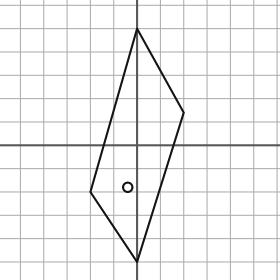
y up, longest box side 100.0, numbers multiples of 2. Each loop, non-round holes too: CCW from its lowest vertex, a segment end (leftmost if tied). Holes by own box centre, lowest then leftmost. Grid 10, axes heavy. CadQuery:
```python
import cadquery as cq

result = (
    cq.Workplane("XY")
    .moveTo(0.0, -50.0)
    .lineTo(20.0, 14.0)
    .lineTo(0.0, 50.0)
    .lineTo(-20.0, -20.0)
    .close()
    .moveTo(-4.0, -18.0)
    .circle(2.0)
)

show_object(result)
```